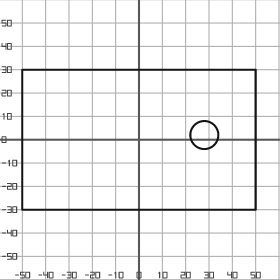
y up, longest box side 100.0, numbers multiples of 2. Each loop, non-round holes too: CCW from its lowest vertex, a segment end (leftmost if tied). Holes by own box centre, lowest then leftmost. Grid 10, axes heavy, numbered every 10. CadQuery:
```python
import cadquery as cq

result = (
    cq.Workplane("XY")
    .moveTo(-50.0, -30.0)
    .lineTo(50.0, -30.0)
    .lineTo(50.0, 30.0)
    .lineTo(-50.0, 30.0)
    .close()
    .moveTo(28.0, 2.0)
    .circle(6.0)
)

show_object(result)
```